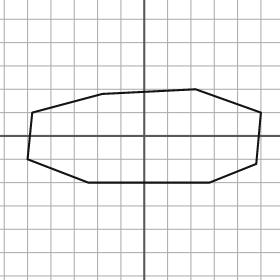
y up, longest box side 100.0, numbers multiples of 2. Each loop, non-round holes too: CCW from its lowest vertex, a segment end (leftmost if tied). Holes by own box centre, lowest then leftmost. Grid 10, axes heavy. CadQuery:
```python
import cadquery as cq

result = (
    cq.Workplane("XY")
    .moveTo(-24.0, -20.0)
    .lineTo(28.0, -20.0)
    .lineTo(48.0, -12.0)
    .lineTo(50.0, 10.0)
    .lineTo(22.0, 20.0)
    .lineTo(-18.0, 18.0)
    .lineTo(-48.0, 10.0)
    .lineTo(-50.0, -10.0)
    .close()
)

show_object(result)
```